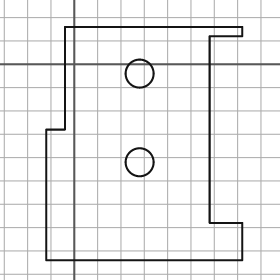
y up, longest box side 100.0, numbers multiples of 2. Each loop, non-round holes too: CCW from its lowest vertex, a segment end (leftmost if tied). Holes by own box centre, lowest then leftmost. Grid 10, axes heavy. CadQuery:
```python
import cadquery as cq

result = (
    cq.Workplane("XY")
    .moveTo(-12.0, -84.0)
    .lineTo(72.0, -84.0)
    .lineTo(72.0, -68.0)
    .lineTo(58.0, -68.0)
    .lineTo(58.0, 12.0)
    .lineTo(72.0, 12.0)
    .lineTo(72.0, 16.0)
    .lineTo(-4.0, 16.0)
    .lineTo(-4.0, -28.0)
    .lineTo(-12.0, -28.0)
    .close()
    .moveTo(28.0, -42.0)
    .circle(6.0)
    .moveTo(28.0, -4.0)
    .circle(6.0)
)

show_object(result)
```